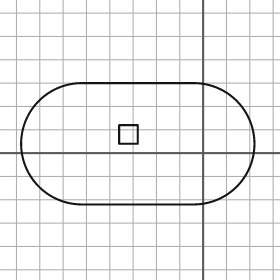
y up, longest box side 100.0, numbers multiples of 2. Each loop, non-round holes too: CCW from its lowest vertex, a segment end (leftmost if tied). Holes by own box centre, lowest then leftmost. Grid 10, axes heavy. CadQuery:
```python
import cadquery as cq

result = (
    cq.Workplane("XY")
    .moveTo(-52.0, -22.0)
    .lineTo(-4.0, -22.0)
    .threePointArc((22.0, 4.0), (-4.0, 30.0))
    .lineTo(-52.0, 30.0)
    .threePointArc((-78.0, 4.0), (-52.0, -22.0))
    .close()
    .moveTo(-36.0, 4.0)
    .lineTo(-28.0, 4.0)
    .lineTo(-28.0, 12.0)
    .lineTo(-36.0, 12.0)
    .close()
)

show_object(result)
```